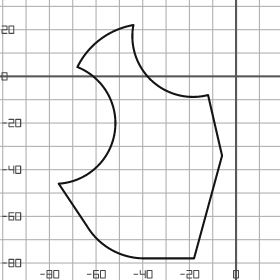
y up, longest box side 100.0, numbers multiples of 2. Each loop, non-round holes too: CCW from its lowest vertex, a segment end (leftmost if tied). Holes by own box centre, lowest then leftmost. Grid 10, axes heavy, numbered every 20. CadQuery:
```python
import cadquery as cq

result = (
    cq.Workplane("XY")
    .moveTo(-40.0, -78.0)
    .lineTo(-18.0, -78.0)
    .lineTo(-6.0, -34.0)
    .lineTo(-12.0, -8.0)
    .threePointArc((-36.0, -2.0), (-44.0, 22.0))
    .threePointArc((-58.0, 16.0), (-68.0, 4.0))
    .threePointArc((-52.0, -24.0), (-76.0, -46.0))
    .lineTo(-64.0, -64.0)
    .threePointArc((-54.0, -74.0), (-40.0, -78.0))
    .close()
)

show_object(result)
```